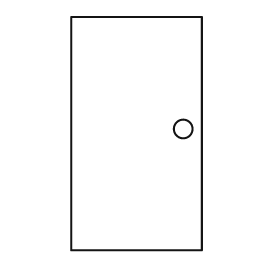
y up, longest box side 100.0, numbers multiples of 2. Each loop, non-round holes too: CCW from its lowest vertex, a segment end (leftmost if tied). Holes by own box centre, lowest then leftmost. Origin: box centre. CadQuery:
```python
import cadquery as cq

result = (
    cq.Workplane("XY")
    .moveTo(-28.0, -50.0)
    .lineTo(28.0, -50.0)
    .lineTo(28.0, 50.0)
    .lineTo(-28.0, 50.0)
    .close()
    .moveTo(20.0, 2.0)
    .circle(4.0)
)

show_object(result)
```